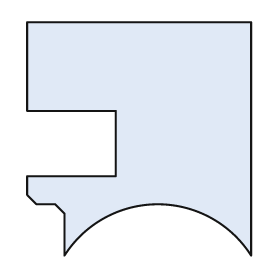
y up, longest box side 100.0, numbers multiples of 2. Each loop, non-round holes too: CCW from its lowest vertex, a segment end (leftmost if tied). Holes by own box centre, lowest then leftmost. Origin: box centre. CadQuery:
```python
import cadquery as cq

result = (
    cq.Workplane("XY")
    .moveTo(-32.0, -50.0)
    .threePointArc((8.0, -28.0), (48.0, -50.0))
    .lineTo(48.0, 50.0)
    .lineTo(-48.0, 50.0)
    .lineTo(-48.0, 12.0)
    .lineTo(-10.0, 12.0)
    .lineTo(-10.0, -16.0)
    .lineTo(-48.0, -16.0)
    .lineTo(-48.0, -24.0)
    .lineTo(-44.0, -28.0)
    .lineTo(-36.0, -28.0)
    .lineTo(-32.0, -32.0)
    .close()
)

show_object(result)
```